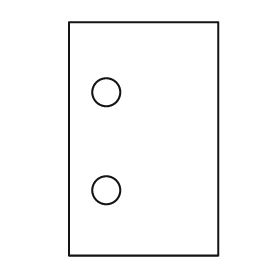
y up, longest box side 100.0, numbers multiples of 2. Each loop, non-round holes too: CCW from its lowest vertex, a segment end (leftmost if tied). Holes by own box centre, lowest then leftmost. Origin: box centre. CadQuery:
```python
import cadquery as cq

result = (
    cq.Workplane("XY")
    .moveTo(-32.0, -50.0)
    .lineTo(32.0, -50.0)
    .lineTo(32.0, 50.0)
    .lineTo(-32.0, 50.0)
    .close()
    .moveTo(-16.0, -22.0)
    .circle(6.0)
    .moveTo(-16.0, 20.0)
    .circle(6.0)
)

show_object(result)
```